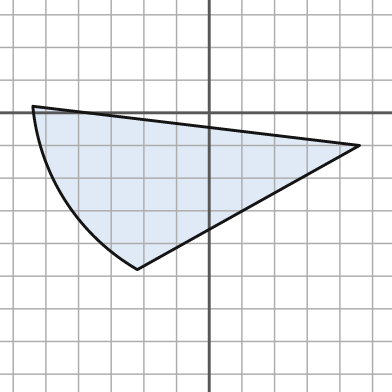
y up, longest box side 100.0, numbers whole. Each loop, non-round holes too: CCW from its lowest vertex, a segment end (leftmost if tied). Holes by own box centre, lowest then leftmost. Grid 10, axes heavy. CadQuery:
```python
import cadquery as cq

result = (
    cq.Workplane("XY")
    .moveTo(-22.0, -48.0)
    .lineTo(46.0, -10.0)
    .lineTo(-54.0, 2.0)
    .threePointArc((-44.0, -27.0), (-22.0, -48.0))
    .close()
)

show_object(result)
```